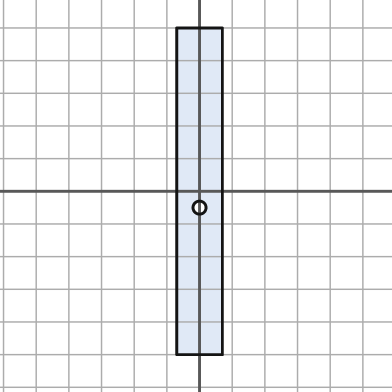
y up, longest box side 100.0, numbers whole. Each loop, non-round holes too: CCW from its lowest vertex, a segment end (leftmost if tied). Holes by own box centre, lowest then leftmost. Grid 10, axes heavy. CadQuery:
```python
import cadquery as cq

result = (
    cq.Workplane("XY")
    .moveTo(-7.0, -50.0)
    .lineTo(7.0, -50.0)
    .lineTo(7.0, 50.0)
    .lineTo(-7.0, 50.0)
    .close()
    .moveTo(0.0, -5.0)
    .circle(2.0)
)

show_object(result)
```